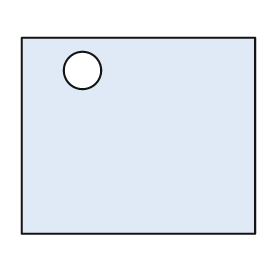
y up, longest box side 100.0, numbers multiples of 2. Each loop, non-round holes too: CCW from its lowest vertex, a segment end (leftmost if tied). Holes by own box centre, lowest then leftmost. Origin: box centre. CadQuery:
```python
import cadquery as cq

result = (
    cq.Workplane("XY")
    .moveTo(-50.0, -42.0)
    .lineTo(50.0, -42.0)
    .lineTo(50.0, 42.0)
    .lineTo(-50.0, 42.0)
    .close()
    .moveTo(-24.0, 28.0)
    .circle(8.0)
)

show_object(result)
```